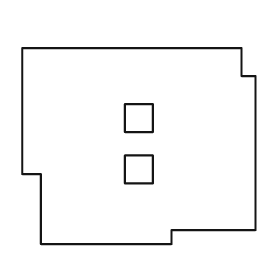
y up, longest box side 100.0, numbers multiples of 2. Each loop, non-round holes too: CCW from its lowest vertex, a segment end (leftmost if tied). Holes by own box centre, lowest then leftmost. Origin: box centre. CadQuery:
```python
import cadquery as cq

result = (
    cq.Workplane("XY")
    .moveTo(-42.0, -42.0)
    .lineTo(14.0, -42.0)
    .lineTo(14.0, -36.0)
    .lineTo(50.0, -36.0)
    .lineTo(50.0, 30.0)
    .lineTo(44.0, 30.0)
    .lineTo(44.0, 42.0)
    .lineTo(-50.0, 42.0)
    .lineTo(-50.0, -12.0)
    .lineTo(-42.0, -12.0)
    .close()
    .moveTo(-6.0, -16.0)
    .lineTo(6.0, -16.0)
    .lineTo(6.0, -4.0)
    .lineTo(-6.0, -4.0)
    .close()
    .moveTo(-6.0, 6.0)
    .lineTo(6.0, 6.0)
    .lineTo(6.0, 18.0)
    .lineTo(-6.0, 18.0)
    .close()
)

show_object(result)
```